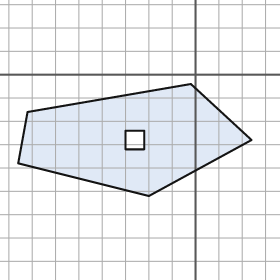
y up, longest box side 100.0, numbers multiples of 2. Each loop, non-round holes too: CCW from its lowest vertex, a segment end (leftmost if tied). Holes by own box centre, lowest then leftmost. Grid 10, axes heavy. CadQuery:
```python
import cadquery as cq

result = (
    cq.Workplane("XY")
    .moveTo(-20.0, -52.0)
    .lineTo(24.0, -28.0)
    .lineTo(-2.0, -4.0)
    .lineTo(-72.0, -16.0)
    .lineTo(-76.0, -38.0)
    .close()
    .moveTo(-30.0, -32.0)
    .lineTo(-22.0, -32.0)
    .lineTo(-22.0, -24.0)
    .lineTo(-30.0, -24.0)
    .close()
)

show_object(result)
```